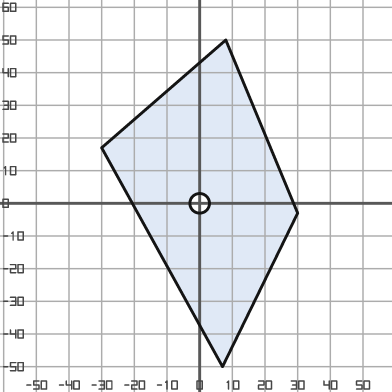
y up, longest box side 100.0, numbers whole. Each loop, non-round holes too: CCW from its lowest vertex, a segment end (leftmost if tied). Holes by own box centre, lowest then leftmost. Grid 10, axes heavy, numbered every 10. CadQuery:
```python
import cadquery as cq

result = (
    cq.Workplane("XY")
    .moveTo(7.0, -50.0)
    .lineTo(30.0, -3.0)
    .lineTo(8.0, 50.0)
    .lineTo(-30.0, 17.0)
    .close()
    .moveTo(0.0, 0.0)
    .circle(3.0)
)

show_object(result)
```